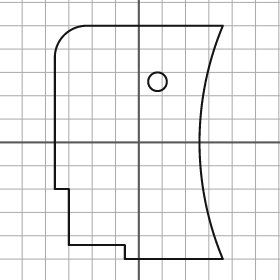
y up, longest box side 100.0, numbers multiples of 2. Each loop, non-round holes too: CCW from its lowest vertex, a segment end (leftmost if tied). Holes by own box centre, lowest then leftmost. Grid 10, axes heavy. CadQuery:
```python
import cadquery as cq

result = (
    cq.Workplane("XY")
    .moveTo(-6.0, -50.0)
    .lineTo(36.0, -50.0)
    .threePointArc((26.0, 0.0), (36.0, 50.0))
    .lineTo(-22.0, 50.0)
    .threePointArc((-32.0, 46.0), (-36.0, 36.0))
    .lineTo(-36.0, -20.0)
    .lineTo(-30.0, -20.0)
    .lineTo(-30.0, -44.0)
    .lineTo(-6.0, -44.0)
    .close()
    .moveTo(8.0, 26.0)
    .circle(4.0)
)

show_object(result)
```